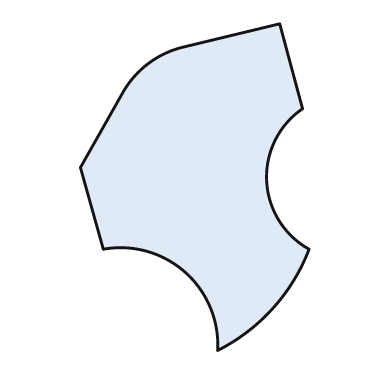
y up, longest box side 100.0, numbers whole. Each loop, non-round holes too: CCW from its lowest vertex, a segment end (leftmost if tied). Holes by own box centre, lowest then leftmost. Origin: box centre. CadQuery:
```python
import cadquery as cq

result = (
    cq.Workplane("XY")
    .moveTo(7.0, -50.0)
    .threePointArc((24.0, -37.0), (35.0, -19.0))
    .threePointArc((22.0, 2.0), (33.0, 24.0))
    .lineTo(26.0, 50.0)
    .lineTo(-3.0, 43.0)
    .threePointArc((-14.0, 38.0), (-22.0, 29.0))
    .lineTo(-35.0, 6.0)
    .lineTo(-28.0, -19.0)
    .threePointArc((-3.0, -26.0), (7.0, -50.0))
    .close()
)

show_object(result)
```